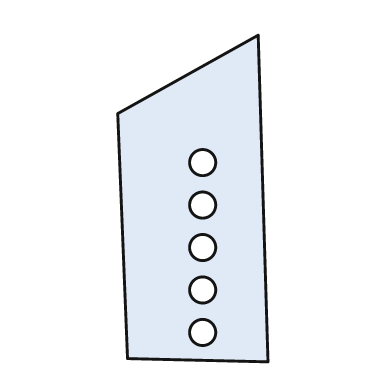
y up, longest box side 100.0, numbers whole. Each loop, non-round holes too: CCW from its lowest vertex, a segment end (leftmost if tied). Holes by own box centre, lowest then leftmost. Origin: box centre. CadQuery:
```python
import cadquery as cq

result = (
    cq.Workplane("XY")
    .moveTo(23.0, -50.0)
    .lineTo(20.0, 50.0)
    .lineTo(-23.0, 26.0)
    .lineTo(-20.0, -49.0)
    .close()
    .moveTo(3.0, -41.0)
    .circle(4.0)
    .moveTo(3.0, -28.0)
    .circle(4.0)
    .moveTo(3.0, -15.0)
    .circle(4.0)
    .moveTo(3.0, -2.0)
    .circle(4.0)
    .moveTo(3.0, 11.0)
    .circle(4.0)
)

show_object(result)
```